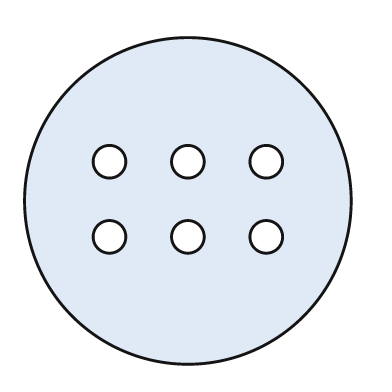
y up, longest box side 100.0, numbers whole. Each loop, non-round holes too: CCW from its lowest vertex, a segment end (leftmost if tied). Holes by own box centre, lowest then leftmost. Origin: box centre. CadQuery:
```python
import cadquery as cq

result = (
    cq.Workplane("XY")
    .moveTo(0.0, 0.0)
    .circle(50.0)
    .moveTo(-24.0, -11.0)
    .circle(5.0)
    .moveTo(0.0, -11.0)
    .circle(5.0)
    .moveTo(24.0, -11.0)
    .circle(5.0)
    .moveTo(-24.0, 12.0)
    .circle(5.0)
    .moveTo(0.0, 12.0)
    .circle(5.0)
    .moveTo(24.0, 12.0)
    .circle(5.0)
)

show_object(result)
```